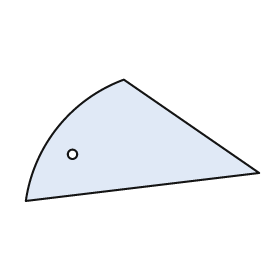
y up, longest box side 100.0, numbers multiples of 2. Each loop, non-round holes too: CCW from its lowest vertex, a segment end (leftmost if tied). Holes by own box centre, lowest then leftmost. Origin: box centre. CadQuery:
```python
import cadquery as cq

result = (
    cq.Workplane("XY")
    .moveTo(-50.0, -26.0)
    .lineTo(50.0, -14.0)
    .lineTo(-8.0, 26.0)
    .threePointArc((-36.0, 6.0), (-50.0, -26.0))
    .close()
    .moveTo(-30.0, -6.0)
    .circle(2.0)
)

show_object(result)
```